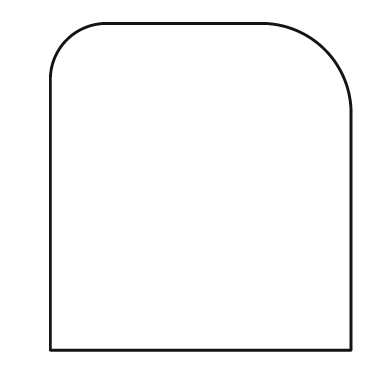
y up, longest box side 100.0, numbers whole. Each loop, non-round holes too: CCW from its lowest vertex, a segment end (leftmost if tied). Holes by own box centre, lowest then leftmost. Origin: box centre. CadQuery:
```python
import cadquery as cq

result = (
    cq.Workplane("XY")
    .moveTo(-46.0, -50.0)
    .lineTo(46.0, -50.0)
    .lineTo(46.0, 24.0)
    .threePointArc((38.0, 42.0), (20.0, 50.0))
    .lineTo(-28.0, 50.0)
    .threePointArc((-41.0, 45.0), (-46.0, 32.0))
    .close()
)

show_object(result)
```